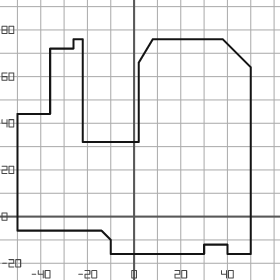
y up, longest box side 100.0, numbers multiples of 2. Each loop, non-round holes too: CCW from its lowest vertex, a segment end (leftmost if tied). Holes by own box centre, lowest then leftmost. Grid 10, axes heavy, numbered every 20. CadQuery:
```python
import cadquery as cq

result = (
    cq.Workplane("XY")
    .moveTo(-10.0, -16.0)
    .lineTo(30.0, -16.0)
    .lineTo(30.0, -12.0)
    .lineTo(40.0, -12.0)
    .lineTo(40.0, -16.0)
    .lineTo(50.0, -16.0)
    .lineTo(50.0, 64.0)
    .lineTo(38.0, 76.0)
    .lineTo(8.0, 76.0)
    .lineTo(2.0, 66.0)
    .lineTo(2.0, 32.0)
    .lineTo(-22.0, 32.0)
    .lineTo(-22.0, 76.0)
    .lineTo(-26.0, 76.0)
    .lineTo(-26.0, 72.0)
    .lineTo(-36.0, 72.0)
    .lineTo(-36.0, 44.0)
    .lineTo(-50.0, 44.0)
    .lineTo(-50.0, -6.0)
    .lineTo(-14.0, -6.0)
    .lineTo(-10.0, -10.0)
    .close()
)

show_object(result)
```